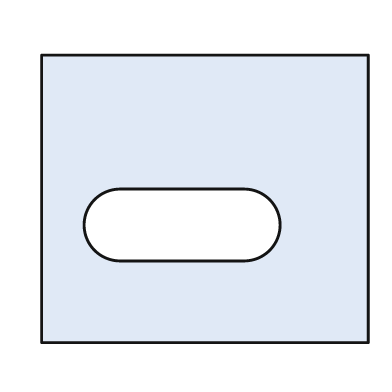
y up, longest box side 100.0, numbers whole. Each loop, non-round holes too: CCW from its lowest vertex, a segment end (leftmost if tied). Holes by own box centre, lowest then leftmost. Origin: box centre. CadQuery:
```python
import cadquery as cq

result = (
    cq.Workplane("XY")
    .moveTo(-50.0, -44.0)
    .lineTo(50.0, -44.0)
    .lineTo(50.0, 44.0)
    .lineTo(-50.0, 44.0)
    .close()
    .moveTo(-26.0, -19.0)
    .lineTo(12.0, -19.0)
    .threePointArc((23.0, -8.0), (12.0, 3.0))
    .lineTo(-26.0, 3.0)
    .threePointArc((-37.0, -8.0), (-26.0, -19.0))
    .close()
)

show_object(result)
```